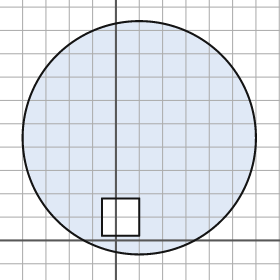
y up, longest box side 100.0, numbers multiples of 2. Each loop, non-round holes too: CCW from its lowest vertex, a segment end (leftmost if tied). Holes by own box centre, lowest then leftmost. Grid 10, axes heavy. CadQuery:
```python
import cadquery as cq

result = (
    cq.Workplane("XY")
    .moveTo(10.0, 44.0)
    .circle(50.0)
    .moveTo(-6.0, 2.0)
    .lineTo(10.0, 2.0)
    .lineTo(10.0, 18.0)
    .lineTo(-6.0, 18.0)
    .close()
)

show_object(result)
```